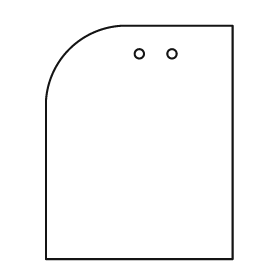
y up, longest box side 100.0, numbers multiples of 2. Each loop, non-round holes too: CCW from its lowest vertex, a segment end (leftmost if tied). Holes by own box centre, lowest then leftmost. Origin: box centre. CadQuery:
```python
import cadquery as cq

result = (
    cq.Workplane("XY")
    .moveTo(-40.0, -50.0)
    .lineTo(40.0, -50.0)
    .lineTo(40.0, 50.0)
    .lineTo(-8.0, 50.0)
    .threePointArc((-30.0, 40.0), (-40.0, 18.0))
    .close()
    .moveTo(0.0, 38.0)
    .circle(2.0)
    .moveTo(14.0, 38.0)
    .circle(2.0)
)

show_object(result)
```